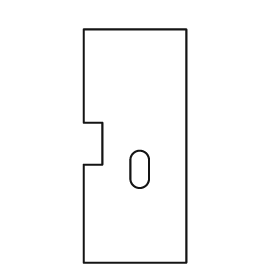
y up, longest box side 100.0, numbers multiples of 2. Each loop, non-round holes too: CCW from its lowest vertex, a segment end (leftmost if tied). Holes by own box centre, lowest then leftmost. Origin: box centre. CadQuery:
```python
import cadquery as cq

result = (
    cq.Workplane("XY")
    .moveTo(-22.0, -50.0)
    .lineTo(22.0, -50.0)
    .lineTo(22.0, 50.0)
    .lineTo(-22.0, 50.0)
    .lineTo(-22.0, 10.0)
    .lineTo(-14.0, 10.0)
    .lineTo(-14.0, -8.0)
    .lineTo(-22.0, -8.0)
    .close()
    .moveTo(-2.0, -14.0)
    .threePointArc((2.0, -18.0), (6.0, -14.0))
    .lineTo(6.0, -6.0)
    .threePointArc((2.0, -2.0), (-2.0, -6.0))
    .close()
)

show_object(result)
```